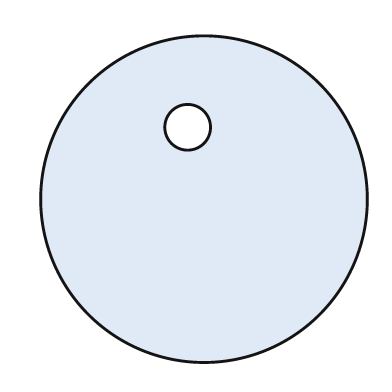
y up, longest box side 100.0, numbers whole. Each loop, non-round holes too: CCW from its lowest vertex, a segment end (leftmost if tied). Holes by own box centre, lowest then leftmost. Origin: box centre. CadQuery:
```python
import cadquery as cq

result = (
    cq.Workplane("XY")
    .moveTo(0.0, 0.0)
    .circle(50.0)
    .moveTo(-5.0, 22.0)
    .circle(7.0)
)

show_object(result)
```